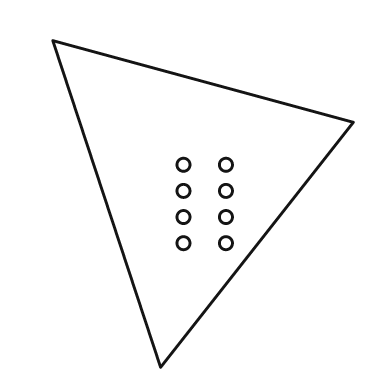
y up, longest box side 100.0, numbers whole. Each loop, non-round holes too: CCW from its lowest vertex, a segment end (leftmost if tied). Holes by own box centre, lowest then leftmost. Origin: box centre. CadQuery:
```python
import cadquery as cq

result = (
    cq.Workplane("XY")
    .moveTo(-13.0, -50.0)
    .lineTo(46.0, 25.0)
    .lineTo(-46.0, 50.0)
    .close()
    .moveTo(-6.0, -12.0)
    .circle(2.0)
    .moveTo(7.0, -12.0)
    .circle(2.0)
    .moveTo(-6.0, -4.0)
    .circle(2.0)
    .moveTo(7.0, -4.0)
    .circle(2.0)
    .moveTo(-6.0, 4.0)
    .circle(2.0)
    .moveTo(7.0, 4.0)
    .circle(2.0)
    .moveTo(-6.0, 12.0)
    .circle(2.0)
    .moveTo(7.0, 12.0)
    .circle(2.0)
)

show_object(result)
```